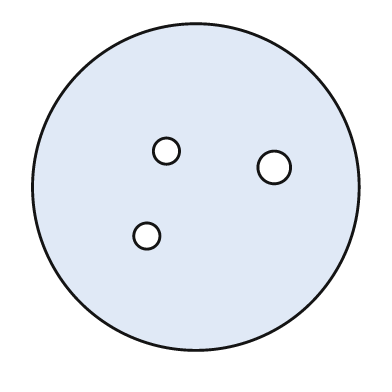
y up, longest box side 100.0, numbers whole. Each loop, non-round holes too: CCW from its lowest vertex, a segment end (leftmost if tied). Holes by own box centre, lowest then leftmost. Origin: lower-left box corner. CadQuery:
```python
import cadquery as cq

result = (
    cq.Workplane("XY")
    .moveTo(50.0, 50.0)
    .circle(50.0)
    .moveTo(35.0, 35.0)
    .circle(4.0)
    .moveTo(74.0, 56.0)
    .circle(5.0)
    .moveTo(41.0, 61.0)
    .circle(4.0)
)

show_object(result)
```